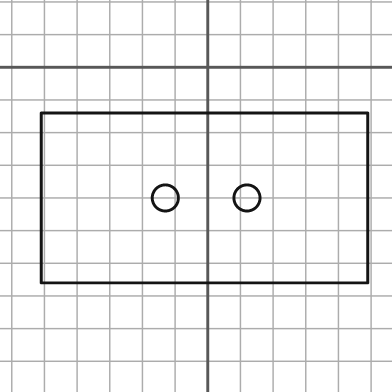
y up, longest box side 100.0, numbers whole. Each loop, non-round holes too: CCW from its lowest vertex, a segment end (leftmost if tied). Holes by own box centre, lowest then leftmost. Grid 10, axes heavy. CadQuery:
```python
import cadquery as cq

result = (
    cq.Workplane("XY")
    .moveTo(-51.0, -66.0)
    .lineTo(49.0, -66.0)
    .lineTo(49.0, -14.0)
    .lineTo(-51.0, -14.0)
    .close()
    .moveTo(-13.0, -40.0)
    .circle(4.0)
    .moveTo(12.0, -40.0)
    .circle(4.0)
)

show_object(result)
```